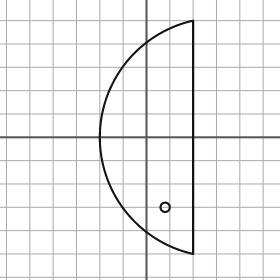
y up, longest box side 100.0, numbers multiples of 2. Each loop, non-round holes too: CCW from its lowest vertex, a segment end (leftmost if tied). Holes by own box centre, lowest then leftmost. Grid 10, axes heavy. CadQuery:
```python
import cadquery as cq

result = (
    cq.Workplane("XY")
    .moveTo(20.0, -50.0)
    .lineTo(20.0, 50.0)
    .threePointArc((-20.0, 0.0), (20.0, -50.0))
    .close()
    .moveTo(8.0, -30.0)
    .circle(2.0)
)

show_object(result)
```